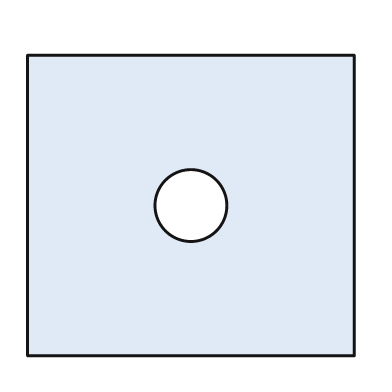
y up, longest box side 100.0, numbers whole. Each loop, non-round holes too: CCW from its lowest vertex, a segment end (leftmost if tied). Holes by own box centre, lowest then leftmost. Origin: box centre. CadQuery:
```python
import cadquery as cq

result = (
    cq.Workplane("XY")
    .moveTo(-50.0, -46.0)
    .lineTo(50.0, -46.0)
    .lineTo(50.0, 46.0)
    .lineTo(-50.0, 46.0)
    .close()
    .moveTo(0.0, 0.0)
    .circle(11.0)
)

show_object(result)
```